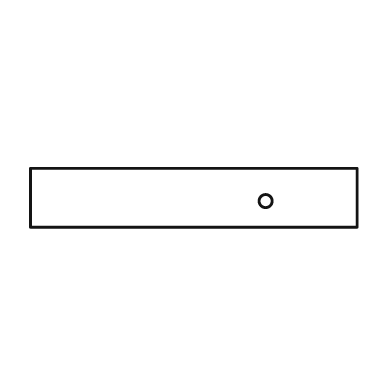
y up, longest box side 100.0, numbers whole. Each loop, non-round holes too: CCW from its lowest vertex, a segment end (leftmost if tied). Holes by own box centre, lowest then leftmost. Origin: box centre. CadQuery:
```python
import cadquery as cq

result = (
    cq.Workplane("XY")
    .moveTo(-50.0, -9.0)
    .lineTo(50.0, -9.0)
    .lineTo(50.0, 9.0)
    .lineTo(-50.0, 9.0)
    .close()
    .moveTo(22.0, -1.0)
    .circle(2.0)
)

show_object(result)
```